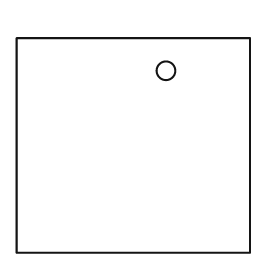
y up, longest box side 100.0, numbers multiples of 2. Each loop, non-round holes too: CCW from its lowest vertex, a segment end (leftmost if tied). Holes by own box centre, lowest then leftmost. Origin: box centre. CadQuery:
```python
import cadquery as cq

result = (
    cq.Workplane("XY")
    .moveTo(-50.0, -46.0)
    .lineTo(50.0, -46.0)
    .lineTo(50.0, 46.0)
    .lineTo(-50.0, 46.0)
    .close()
    .moveTo(14.0, 32.0)
    .circle(4.0)
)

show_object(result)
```